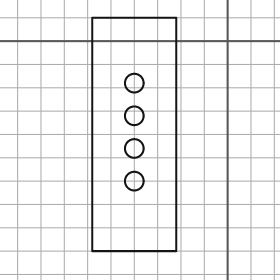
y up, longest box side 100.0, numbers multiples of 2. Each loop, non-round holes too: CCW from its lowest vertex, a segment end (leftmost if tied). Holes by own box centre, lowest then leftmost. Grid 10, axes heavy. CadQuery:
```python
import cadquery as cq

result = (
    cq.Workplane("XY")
    .moveTo(-58.0, -90.0)
    .lineTo(-22.0, -90.0)
    .lineTo(-22.0, 10.0)
    .lineTo(-58.0, 10.0)
    .close()
    .moveTo(-40.0, -60.0)
    .circle(4.0)
    .moveTo(-40.0, -46.0)
    .circle(4.0)
    .moveTo(-40.0, -32.0)
    .circle(4.0)
    .moveTo(-40.0, -18.0)
    .circle(4.0)
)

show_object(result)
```